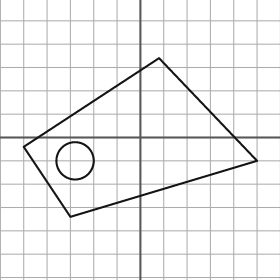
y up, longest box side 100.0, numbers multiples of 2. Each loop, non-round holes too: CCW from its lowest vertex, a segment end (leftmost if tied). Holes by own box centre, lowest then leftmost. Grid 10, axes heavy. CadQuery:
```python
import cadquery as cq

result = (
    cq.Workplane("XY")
    .moveTo(-30.0, -34.0)
    .lineTo(50.0, -10.0)
    .lineTo(8.0, 34.0)
    .lineTo(-50.0, -4.0)
    .close()
    .moveTo(-28.0, -10.0)
    .circle(8.0)
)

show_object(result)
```